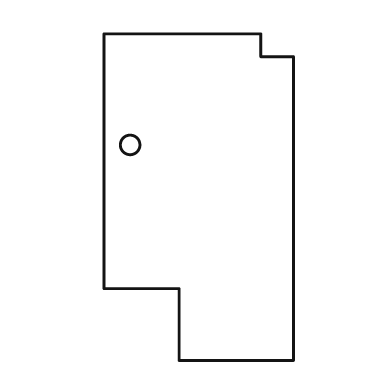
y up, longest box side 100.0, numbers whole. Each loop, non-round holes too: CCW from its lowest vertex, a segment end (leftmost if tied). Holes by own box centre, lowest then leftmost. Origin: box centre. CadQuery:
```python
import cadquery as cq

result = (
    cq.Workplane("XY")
    .moveTo(-6.0, -50.0)
    .lineTo(29.0, -50.0)
    .lineTo(29.0, 43.0)
    .lineTo(19.0, 43.0)
    .lineTo(19.0, 50.0)
    .lineTo(-29.0, 50.0)
    .lineTo(-29.0, -28.0)
    .lineTo(-6.0, -28.0)
    .close()
    .moveTo(-21.0, 16.0)
    .circle(3.0)
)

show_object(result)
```